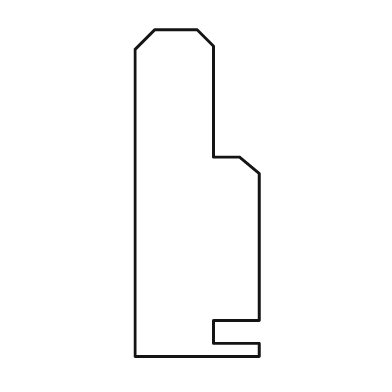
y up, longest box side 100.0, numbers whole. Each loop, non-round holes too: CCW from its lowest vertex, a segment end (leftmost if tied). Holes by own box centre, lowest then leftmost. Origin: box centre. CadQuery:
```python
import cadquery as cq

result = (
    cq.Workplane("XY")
    .moveTo(-19.0, -50.0)
    .lineTo(19.0, -50.0)
    .lineTo(19.0, -46.0)
    .lineTo(5.0, -46.0)
    .lineTo(5.0, -39.0)
    .lineTo(19.0, -39.0)
    .lineTo(19.0, 6.0)
    .lineTo(13.0, 11.0)
    .lineTo(5.0, 11.0)
    .lineTo(5.0, 45.0)
    .lineTo(0.0, 50.0)
    .lineTo(-13.0, 50.0)
    .lineTo(-19.0, 44.0)
    .close()
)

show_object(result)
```